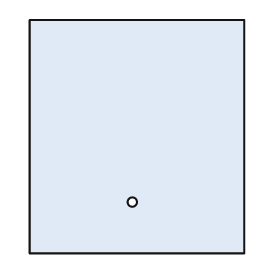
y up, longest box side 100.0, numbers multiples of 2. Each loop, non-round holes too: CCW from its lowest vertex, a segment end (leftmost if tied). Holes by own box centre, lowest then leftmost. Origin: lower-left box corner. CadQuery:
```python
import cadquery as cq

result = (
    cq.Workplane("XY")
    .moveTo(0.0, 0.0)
    .lineTo(92.0, 0.0)
    .lineTo(92.0, 100.0)
    .lineTo(0.0, 100.0)
    .close()
    .moveTo(44.0, 22.0)
    .circle(2.0)
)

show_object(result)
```